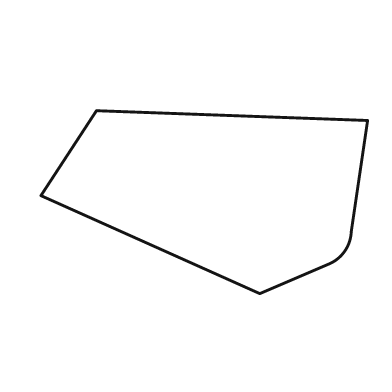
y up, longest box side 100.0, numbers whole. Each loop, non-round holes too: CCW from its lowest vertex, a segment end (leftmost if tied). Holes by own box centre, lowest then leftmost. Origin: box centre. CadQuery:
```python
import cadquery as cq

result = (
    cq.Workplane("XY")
    .moveTo(17.0, -28.0)
    .lineTo(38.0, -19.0)
    .threePointArc((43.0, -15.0), (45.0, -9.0))
    .lineTo(50.0, 25.0)
    .lineTo(-33.0, 28.0)
    .lineTo(-50.0, 2.0)
    .close()
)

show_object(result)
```